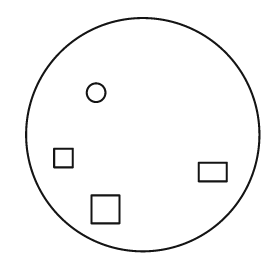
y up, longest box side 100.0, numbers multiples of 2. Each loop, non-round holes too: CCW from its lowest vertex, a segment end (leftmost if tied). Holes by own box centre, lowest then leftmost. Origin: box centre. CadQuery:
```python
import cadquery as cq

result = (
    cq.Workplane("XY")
    .moveTo(0.0, 0.0)
    .circle(50.0)
    .moveTo(-22.0, -38.0)
    .lineTo(-10.0, -38.0)
    .lineTo(-10.0, -26.0)
    .lineTo(-22.0, -26.0)
    .close()
    .moveTo(24.0, -20.0)
    .lineTo(36.0, -20.0)
    .lineTo(36.0, -12.0)
    .lineTo(24.0, -12.0)
    .close()
    .moveTo(-38.0, -14.0)
    .lineTo(-30.0, -14.0)
    .lineTo(-30.0, -6.0)
    .lineTo(-38.0, -6.0)
    .close()
    .moveTo(-20.0, 18.0)
    .circle(4.0)
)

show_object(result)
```